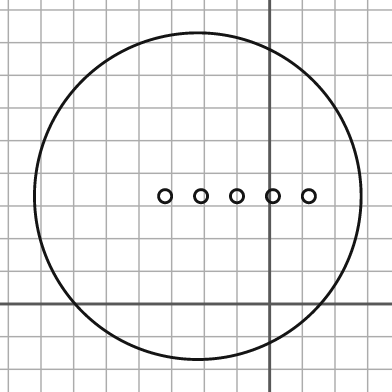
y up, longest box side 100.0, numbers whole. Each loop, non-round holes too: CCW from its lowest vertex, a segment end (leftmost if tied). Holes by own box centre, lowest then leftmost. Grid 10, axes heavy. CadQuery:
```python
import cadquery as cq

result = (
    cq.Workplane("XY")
    .moveTo(-22.0, 33.0)
    .circle(50.0)
    .moveTo(-32.0, 33.0)
    .circle(2.0)
    .moveTo(-21.0, 33.0)
    .circle(2.0)
    .moveTo(-10.0, 33.0)
    .circle(2.0)
    .moveTo(1.0, 33.0)
    .circle(2.0)
    .moveTo(12.0, 33.0)
    .circle(2.0)
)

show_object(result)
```